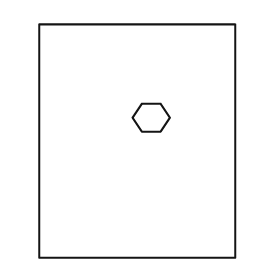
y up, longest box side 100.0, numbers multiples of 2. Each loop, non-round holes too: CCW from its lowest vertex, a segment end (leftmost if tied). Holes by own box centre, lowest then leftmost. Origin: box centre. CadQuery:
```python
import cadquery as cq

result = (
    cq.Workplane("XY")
    .moveTo(-42.0, -50.0)
    .lineTo(42.0, -50.0)
    .lineTo(42.0, 50.0)
    .lineTo(-42.0, 50.0)
    .close()
    .moveTo(2.0, 4.0)
    .lineTo(10.0, 4.0)
    .lineTo(14.0, 10.0)
    .lineTo(10.0, 16.0)
    .lineTo(2.0, 16.0)
    .lineTo(-2.0, 10.0)
    .close()
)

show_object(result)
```